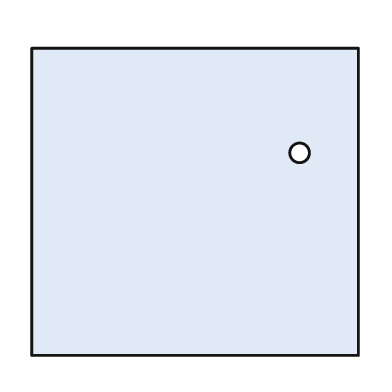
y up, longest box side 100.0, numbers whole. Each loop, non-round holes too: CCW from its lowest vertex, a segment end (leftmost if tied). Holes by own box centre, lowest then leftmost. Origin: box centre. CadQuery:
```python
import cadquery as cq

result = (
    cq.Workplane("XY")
    .moveTo(-50.0, -47.0)
    .lineTo(50.0, -47.0)
    .lineTo(50.0, 47.0)
    .lineTo(-50.0, 47.0)
    .close()
    .moveTo(32.0, 15.0)
    .circle(3.0)
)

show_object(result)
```